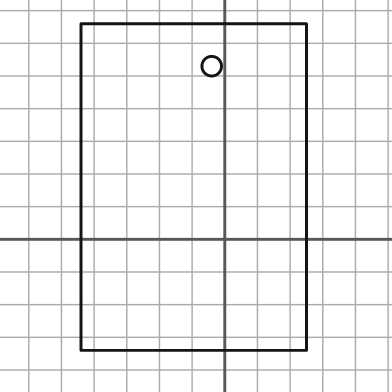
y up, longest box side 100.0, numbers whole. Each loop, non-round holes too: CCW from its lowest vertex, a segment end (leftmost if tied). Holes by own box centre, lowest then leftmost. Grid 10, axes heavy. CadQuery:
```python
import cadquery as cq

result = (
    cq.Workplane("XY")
    .moveTo(-44.0, -34.0)
    .lineTo(25.0, -34.0)
    .lineTo(25.0, 66.0)
    .lineTo(-44.0, 66.0)
    .close()
    .moveTo(-4.0, 53.0)
    .circle(3.0)
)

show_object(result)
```